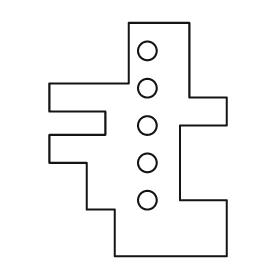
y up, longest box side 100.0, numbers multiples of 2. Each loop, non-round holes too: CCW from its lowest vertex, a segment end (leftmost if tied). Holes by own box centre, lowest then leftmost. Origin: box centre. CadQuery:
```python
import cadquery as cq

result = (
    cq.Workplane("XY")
    .moveTo(-10.0, -50.0)
    .lineTo(38.0, -50.0)
    .lineTo(38.0, -26.0)
    .lineTo(18.0, -26.0)
    .lineTo(18.0, 6.0)
    .lineTo(38.0, 6.0)
    .lineTo(38.0, 18.0)
    .lineTo(22.0, 18.0)
    .lineTo(22.0, 50.0)
    .lineTo(-4.0, 50.0)
    .lineTo(-4.0, 24.0)
    .lineTo(-38.0, 24.0)
    .lineTo(-38.0, 12.0)
    .lineTo(-14.0, 12.0)
    .lineTo(-14.0, 2.0)
    .lineTo(-38.0, 2.0)
    .lineTo(-38.0, -10.0)
    .lineTo(-22.0, -10.0)
    .lineTo(-22.0, -30.0)
    .lineTo(-10.0, -30.0)
    .close()
    .moveTo(4.0, -26.0)
    .circle(4.0)
    .moveTo(4.0, -10.0)
    .circle(4.0)
    .moveTo(4.0, 6.0)
    .circle(4.0)
    .moveTo(4.0, 22.0)
    .circle(4.0)
    .moveTo(4.0, 38.0)
    .circle(4.0)
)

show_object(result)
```